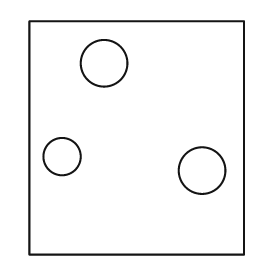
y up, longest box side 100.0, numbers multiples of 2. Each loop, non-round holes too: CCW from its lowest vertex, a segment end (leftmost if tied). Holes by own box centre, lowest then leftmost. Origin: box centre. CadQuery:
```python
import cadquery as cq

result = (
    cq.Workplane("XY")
    .moveTo(-46.0, -50.0)
    .lineTo(46.0, -50.0)
    .lineTo(46.0, 50.0)
    .lineTo(-46.0, 50.0)
    .close()
    .moveTo(28.0, -14.0)
    .circle(10.0)
    .moveTo(-32.0, -8.0)
    .circle(8.0)
    .moveTo(-14.0, 32.0)
    .circle(10.0)
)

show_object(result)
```